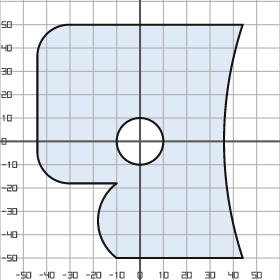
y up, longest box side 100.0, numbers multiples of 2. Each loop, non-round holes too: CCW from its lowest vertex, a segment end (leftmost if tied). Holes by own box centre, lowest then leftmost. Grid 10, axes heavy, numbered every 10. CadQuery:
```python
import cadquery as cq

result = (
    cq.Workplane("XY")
    .moveTo(-10.0, -50.0)
    .lineTo(44.0, -50.0)
    .threePointArc((36.0, 0.0), (44.0, 50.0))
    .lineTo(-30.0, 50.0)
    .threePointArc((-40.0, 46.0), (-44.0, 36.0))
    .lineTo(-44.0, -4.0)
    .threePointArc((-40.0, -14.0), (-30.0, -18.0))
    .lineTo(-10.0, -18.0)
    .threePointArc((-18.0, -34.0), (-10.0, -50.0))
    .close()
    .moveTo(0.0, 0.0)
    .circle(10.0)
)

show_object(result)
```